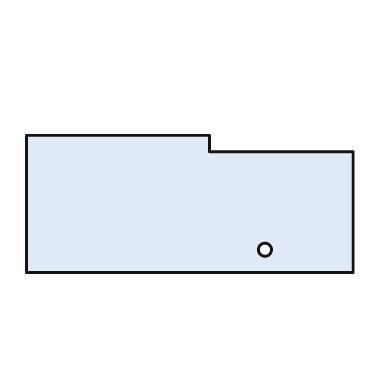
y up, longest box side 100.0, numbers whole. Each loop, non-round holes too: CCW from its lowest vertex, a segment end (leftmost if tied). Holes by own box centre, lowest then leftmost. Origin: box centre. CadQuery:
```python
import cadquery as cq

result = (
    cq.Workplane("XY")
    .moveTo(-50.0, -21.0)
    .lineTo(50.0, -21.0)
    .lineTo(50.0, 16.0)
    .lineTo(6.0, 16.0)
    .lineTo(6.0, 21.0)
    .lineTo(-50.0, 21.0)
    .close()
    .moveTo(23.0, -14.0)
    .circle(2.0)
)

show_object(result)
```